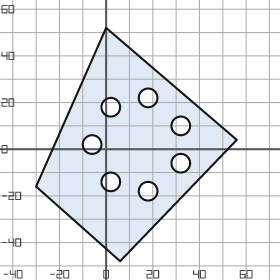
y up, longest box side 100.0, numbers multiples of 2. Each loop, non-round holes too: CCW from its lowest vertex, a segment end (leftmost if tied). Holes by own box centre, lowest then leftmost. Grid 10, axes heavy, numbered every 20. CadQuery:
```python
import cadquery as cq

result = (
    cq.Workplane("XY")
    .moveTo(6.0, -48.0)
    .lineTo(56.0, 4.0)
    .lineTo(0.0, 52.0)
    .lineTo(-30.0, -16.0)
    .close()
    .moveTo(18.0, -18.0)
    .circle(4.0)
    .moveTo(2.0, -14.0)
    .circle(4.0)
    .moveTo(32.0, -6.0)
    .circle(4.0)
    .moveTo(-6.0, 2.0)
    .circle(4.0)
    .moveTo(32.0, 10.0)
    .circle(4.0)
    .moveTo(2.0, 18.0)
    .circle(4.0)
    .moveTo(18.0, 22.0)
    .circle(4.0)
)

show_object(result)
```